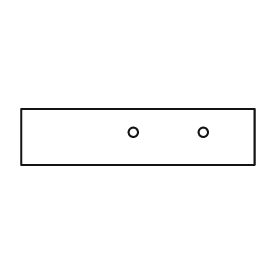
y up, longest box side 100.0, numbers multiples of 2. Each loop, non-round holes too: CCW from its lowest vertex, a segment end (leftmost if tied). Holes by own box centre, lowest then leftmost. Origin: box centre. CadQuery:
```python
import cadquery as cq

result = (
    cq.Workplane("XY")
    .moveTo(-50.0, -12.0)
    .lineTo(50.0, -12.0)
    .lineTo(50.0, 12.0)
    .lineTo(-50.0, 12.0)
    .close()
    .moveTo(-2.0, 2.0)
    .circle(2.0)
    .moveTo(28.0, 2.0)
    .circle(2.0)
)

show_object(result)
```